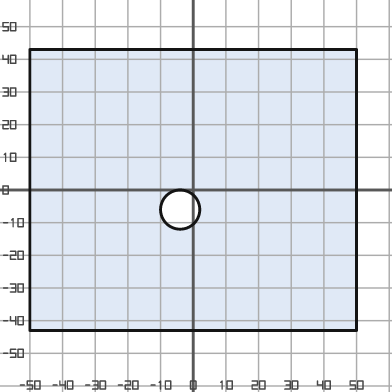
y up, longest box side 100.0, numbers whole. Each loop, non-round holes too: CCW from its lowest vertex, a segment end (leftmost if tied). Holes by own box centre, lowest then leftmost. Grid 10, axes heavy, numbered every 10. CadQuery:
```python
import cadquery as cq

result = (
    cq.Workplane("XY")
    .moveTo(-50.0, -43.0)
    .lineTo(50.0, -43.0)
    .lineTo(50.0, 43.0)
    .lineTo(-50.0, 43.0)
    .close()
    .moveTo(-4.0, -6.0)
    .circle(6.0)
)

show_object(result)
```